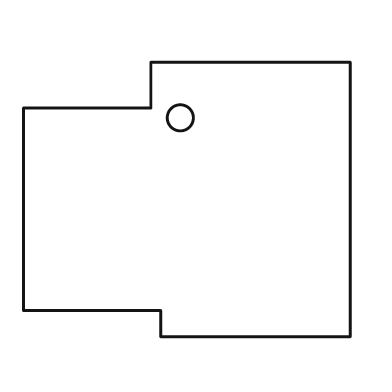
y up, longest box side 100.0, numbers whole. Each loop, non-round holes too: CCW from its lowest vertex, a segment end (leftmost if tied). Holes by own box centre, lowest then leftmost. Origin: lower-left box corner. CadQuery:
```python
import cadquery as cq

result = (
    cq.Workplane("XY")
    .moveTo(42.0, 0.0)
    .lineTo(100.0, 0.0)
    .lineTo(100.0, 84.0)
    .lineTo(39.0, 84.0)
    .lineTo(39.0, 70.0)
    .lineTo(0.0, 70.0)
    .lineTo(0.0, 8.0)
    .lineTo(42.0, 8.0)
    .close()
    .moveTo(48.0, 67.0)
    .circle(4.0)
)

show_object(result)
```